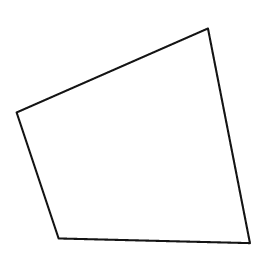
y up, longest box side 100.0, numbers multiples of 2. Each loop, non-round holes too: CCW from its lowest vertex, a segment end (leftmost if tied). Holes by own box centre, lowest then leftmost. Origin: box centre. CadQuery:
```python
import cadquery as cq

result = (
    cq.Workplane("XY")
    .moveTo(50.0, -46.0)
    .lineTo(32.0, 46.0)
    .lineTo(-50.0, 10.0)
    .lineTo(-32.0, -44.0)
    .close()
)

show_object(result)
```